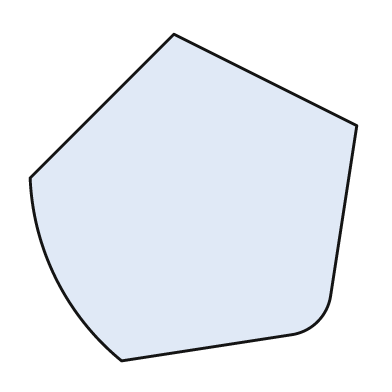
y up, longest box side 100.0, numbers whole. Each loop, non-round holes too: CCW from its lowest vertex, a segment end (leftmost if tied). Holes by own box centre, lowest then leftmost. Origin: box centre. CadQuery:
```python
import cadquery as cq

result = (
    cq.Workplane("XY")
    .moveTo(-22.0, -50.0)
    .lineTo(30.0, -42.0)
    .threePointArc((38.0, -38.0), (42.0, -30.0))
    .lineTo(50.0, 22.0)
    .lineTo(-6.0, 50.0)
    .lineTo(-50.0, 6.0)
    .threePointArc((-42.0, -25.0), (-22.0, -50.0))
    .close()
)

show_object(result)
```